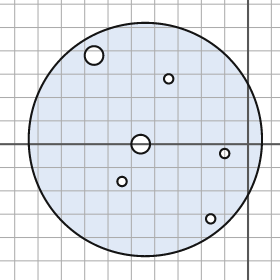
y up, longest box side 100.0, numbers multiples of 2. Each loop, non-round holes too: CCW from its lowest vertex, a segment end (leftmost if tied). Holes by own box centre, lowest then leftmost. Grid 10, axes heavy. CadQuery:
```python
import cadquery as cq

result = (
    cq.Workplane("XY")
    .moveTo(-44.0, 2.0)
    .circle(50.0)
    .moveTo(-16.0, -32.0)
    .circle(2.0)
    .moveTo(-54.0, -16.0)
    .circle(2.0)
    .moveTo(-10.0, -4.0)
    .circle(2.0)
    .moveTo(-46.0, 0.0)
    .circle(4.0)
    .moveTo(-34.0, 28.0)
    .circle(2.0)
    .moveTo(-66.0, 38.0)
    .circle(4.0)
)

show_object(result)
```